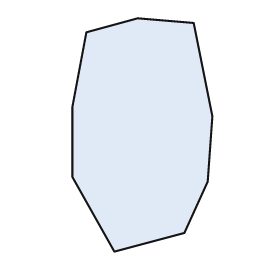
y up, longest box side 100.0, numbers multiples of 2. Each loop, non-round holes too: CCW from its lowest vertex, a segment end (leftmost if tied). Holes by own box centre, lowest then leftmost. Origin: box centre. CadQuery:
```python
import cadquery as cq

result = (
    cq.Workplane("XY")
    .moveTo(-12.0, -50.0)
    .lineTo(18.0, -42.0)
    .lineTo(28.0, -20.0)
    .lineTo(30.0, 8.0)
    .lineTo(22.0, 48.0)
    .lineTo(-2.0, 50.0)
    .lineTo(-24.0, 44.0)
    .lineTo(-30.0, 12.0)
    .lineTo(-30.0, -18.0)
    .close()
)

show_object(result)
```